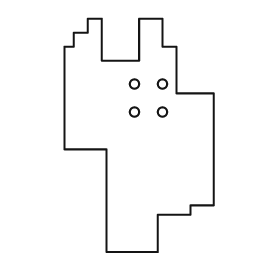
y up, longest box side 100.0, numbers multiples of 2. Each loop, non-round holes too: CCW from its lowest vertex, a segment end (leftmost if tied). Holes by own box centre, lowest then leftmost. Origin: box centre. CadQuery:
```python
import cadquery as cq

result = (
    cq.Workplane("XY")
    .moveTo(-14.0, -50.0)
    .lineTo(8.0, -50.0)
    .lineTo(8.0, -34.0)
    .lineTo(22.0, -34.0)
    .lineTo(22.0, -30.0)
    .lineTo(32.0, -30.0)
    .lineTo(32.0, 18.0)
    .lineTo(16.0, 18.0)
    .lineTo(16.0, 38.0)
    .lineTo(10.0, 38.0)
    .lineTo(10.0, 50.0)
    .lineTo(0.0, 50.0)
    .lineTo(0.0, 32.0)
    .lineTo(-16.0, 32.0)
    .lineTo(-16.0, 50.0)
    .lineTo(-22.0, 50.0)
    .lineTo(-22.0, 44.0)
    .lineTo(-28.0, 44.0)
    .lineTo(-28.0, 38.0)
    .lineTo(-32.0, 38.0)
    .lineTo(-32.0, -6.0)
    .lineTo(-14.0, -6.0)
    .close()
    .moveTo(-2.0, 10.0)
    .circle(2.0)
    .moveTo(10.0, 10.0)
    .circle(2.0)
    .moveTo(-2.0, 22.0)
    .circle(2.0)
    .moveTo(10.0, 22.0)
    .circle(2.0)
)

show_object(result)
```